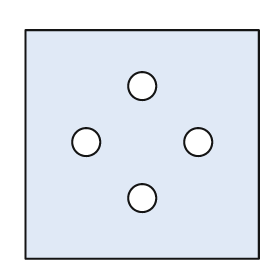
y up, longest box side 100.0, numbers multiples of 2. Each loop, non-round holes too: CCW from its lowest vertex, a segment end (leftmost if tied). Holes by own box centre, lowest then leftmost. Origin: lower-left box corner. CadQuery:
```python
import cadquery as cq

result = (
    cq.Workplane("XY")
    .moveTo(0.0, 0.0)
    .lineTo(100.0, 0.0)
    .lineTo(100.0, 98.0)
    .lineTo(0.0, 98.0)
    .close()
    .moveTo(50.0, 26.0)
    .circle(6.0)
    .moveTo(26.0, 50.0)
    .circle(6.0)
    .moveTo(74.0, 50.0)
    .circle(6.0)
    .moveTo(50.0, 74.0)
    .circle(6.0)
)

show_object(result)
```